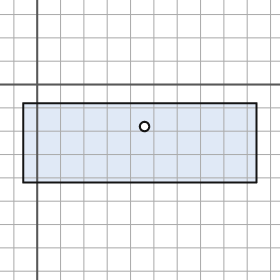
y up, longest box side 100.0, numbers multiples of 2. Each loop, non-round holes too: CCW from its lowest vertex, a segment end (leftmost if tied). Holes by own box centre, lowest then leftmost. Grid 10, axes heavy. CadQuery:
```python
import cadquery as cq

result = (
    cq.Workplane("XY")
    .moveTo(-6.0, -42.0)
    .lineTo(94.0, -42.0)
    .lineTo(94.0, -8.0)
    .lineTo(-6.0, -8.0)
    .close()
    .moveTo(46.0, -18.0)
    .circle(2.0)
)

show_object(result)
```